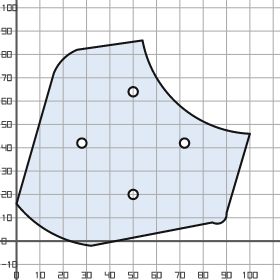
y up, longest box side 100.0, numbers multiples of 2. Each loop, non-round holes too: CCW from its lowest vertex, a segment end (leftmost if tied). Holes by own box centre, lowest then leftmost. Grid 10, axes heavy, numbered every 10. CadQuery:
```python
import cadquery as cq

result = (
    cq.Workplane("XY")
    .moveTo(32.0, -2.0)
    .lineTo(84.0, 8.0)
    .threePointArc((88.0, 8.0), (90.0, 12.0))
    .lineTo(100.0, 46.0)
    .threePointArc((70.0, 58.0), (54.0, 86.0))
    .lineTo(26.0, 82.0)
    .threePointArc((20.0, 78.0), (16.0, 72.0))
    .lineTo(0.0, 16.0)
    .threePointArc((14.0, 4.0), (32.0, -2.0))
    .close()
    .moveTo(50.0, 20.0)
    .circle(2.0)
    .moveTo(28.0, 42.0)
    .circle(2.0)
    .moveTo(72.0, 42.0)
    .circle(2.0)
    .moveTo(50.0, 64.0)
    .circle(2.0)
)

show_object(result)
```